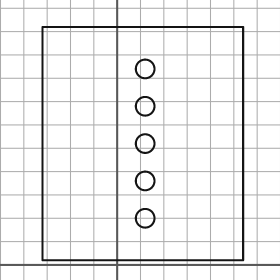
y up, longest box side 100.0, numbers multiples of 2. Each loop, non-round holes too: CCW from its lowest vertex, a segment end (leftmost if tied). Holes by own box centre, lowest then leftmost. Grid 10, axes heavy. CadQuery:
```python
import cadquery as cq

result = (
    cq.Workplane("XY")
    .moveTo(-32.0, 2.0)
    .lineTo(54.0, 2.0)
    .lineTo(54.0, 102.0)
    .lineTo(-32.0, 102.0)
    .close()
    .moveTo(12.0, 20.0)
    .circle(4.0)
    .moveTo(12.0, 36.0)
    .circle(4.0)
    .moveTo(12.0, 52.0)
    .circle(4.0)
    .moveTo(12.0, 68.0)
    .circle(4.0)
    .moveTo(12.0, 84.0)
    .circle(4.0)
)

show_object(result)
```